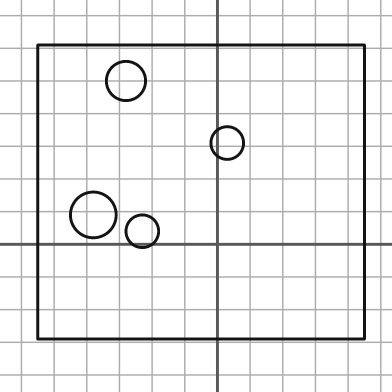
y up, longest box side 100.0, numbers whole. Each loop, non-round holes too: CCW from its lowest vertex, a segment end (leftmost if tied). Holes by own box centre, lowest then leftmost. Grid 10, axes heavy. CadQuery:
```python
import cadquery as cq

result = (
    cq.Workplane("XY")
    .moveTo(-55.0, -29.0)
    .lineTo(45.0, -29.0)
    .lineTo(45.0, 61.0)
    .lineTo(-55.0, 61.0)
    .close()
    .moveTo(-23.0, 4.0)
    .circle(5.0)
    .moveTo(-38.0, 9.0)
    .circle(7.0)
    .moveTo(3.0, 31.0)
    .circle(5.0)
    .moveTo(-28.0, 50.0)
    .circle(6.0)
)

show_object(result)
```